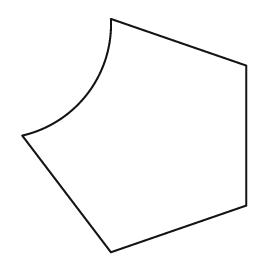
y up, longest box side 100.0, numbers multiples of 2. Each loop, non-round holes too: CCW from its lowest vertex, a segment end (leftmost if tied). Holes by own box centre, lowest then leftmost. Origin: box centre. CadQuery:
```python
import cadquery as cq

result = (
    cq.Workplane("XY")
    .moveTo(-10.0, -50.0)
    .lineTo(48.0, -30.0)
    .lineTo(48.0, 30.0)
    .lineTo(-10.0, 50.0)
    .threePointArc((-20.0, 18.0), (-48.0, 0.0))
    .close()
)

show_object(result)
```